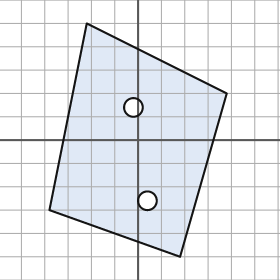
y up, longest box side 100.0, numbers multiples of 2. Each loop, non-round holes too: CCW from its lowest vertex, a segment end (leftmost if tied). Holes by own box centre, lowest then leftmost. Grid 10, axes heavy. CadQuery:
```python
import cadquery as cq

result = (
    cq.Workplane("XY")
    .moveTo(18.0, -50.0)
    .lineTo(38.0, 20.0)
    .lineTo(-22.0, 50.0)
    .lineTo(-38.0, -30.0)
    .close()
    .moveTo(4.0, -26.0)
    .circle(4.0)
    .moveTo(-2.0, 14.0)
    .circle(4.0)
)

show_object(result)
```